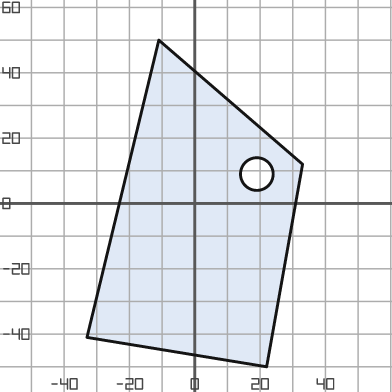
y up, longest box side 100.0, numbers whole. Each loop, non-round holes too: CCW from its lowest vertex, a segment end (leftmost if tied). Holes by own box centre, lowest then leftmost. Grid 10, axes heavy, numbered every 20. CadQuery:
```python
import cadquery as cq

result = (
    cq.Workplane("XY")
    .moveTo(22.0, -50.0)
    .lineTo(33.0, 12.0)
    .lineTo(-11.0, 50.0)
    .lineTo(-33.0, -41.0)
    .close()
    .moveTo(19.0, 9.0)
    .circle(5.0)
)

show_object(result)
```